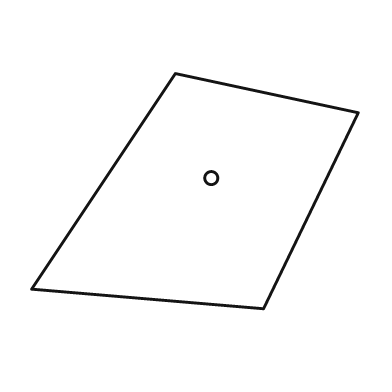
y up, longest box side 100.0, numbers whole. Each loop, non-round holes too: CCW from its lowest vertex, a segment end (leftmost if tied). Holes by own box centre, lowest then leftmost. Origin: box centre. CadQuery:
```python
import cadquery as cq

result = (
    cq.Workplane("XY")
    .moveTo(21.0, -36.0)
    .lineTo(50.0, 24.0)
    .lineTo(-6.0, 36.0)
    .lineTo(-50.0, -30.0)
    .close()
    .moveTo(5.0, 4.0)
    .circle(2.0)
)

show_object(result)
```